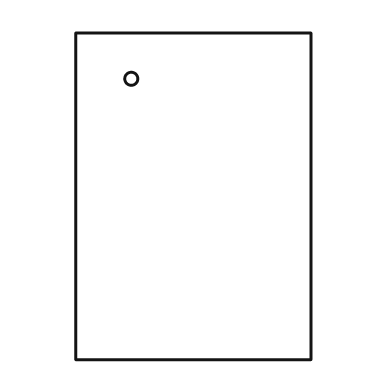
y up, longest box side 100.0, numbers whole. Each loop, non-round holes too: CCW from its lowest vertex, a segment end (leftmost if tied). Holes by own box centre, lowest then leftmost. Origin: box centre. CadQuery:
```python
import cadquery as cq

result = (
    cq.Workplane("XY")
    .moveTo(-36.0, -50.0)
    .lineTo(36.0, -50.0)
    .lineTo(36.0, 50.0)
    .lineTo(-36.0, 50.0)
    .close()
    .moveTo(-19.0, 36.0)
    .circle(2.0)
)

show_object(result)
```